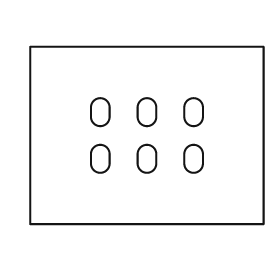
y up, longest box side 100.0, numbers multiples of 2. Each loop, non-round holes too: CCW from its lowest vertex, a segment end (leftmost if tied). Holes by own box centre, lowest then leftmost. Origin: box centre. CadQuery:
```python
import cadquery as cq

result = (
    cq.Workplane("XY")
    .moveTo(-50.0, -38.0)
    .lineTo(50.0, -38.0)
    .lineTo(50.0, 38.0)
    .lineTo(-50.0, 38.0)
    .close()
    .moveTo(-24.0, -12.0)
    .threePointArc((-20.0, -16.0), (-16.0, -12.0))
    .lineTo(-16.0, -8.0)
    .threePointArc((-20.0, -4.0), (-24.0, -8.0))
    .close()
    .moveTo(-4.0, -12.0)
    .threePointArc((0.0, -16.0), (4.0, -12.0))
    .lineTo(4.0, -8.0)
    .threePointArc((0.0, -4.0), (-4.0, -8.0))
    .close()
    .moveTo(16.0, -12.0)
    .threePointArc((20.0, -16.0), (24.0, -12.0))
    .lineTo(24.0, -8.0)
    .threePointArc((20.0, -4.0), (16.0, -8.0))
    .close()
    .moveTo(-24.0, 8.0)
    .threePointArc((-20.0, 4.0), (-16.0, 8.0))
    .lineTo(-16.0, 12.0)
    .threePointArc((-20.0, 16.0), (-24.0, 12.0))
    .close()
    .moveTo(-4.0, 8.0)
    .threePointArc((0.0, 4.0), (4.0, 8.0))
    .lineTo(4.0, 12.0)
    .threePointArc((0.0, 16.0), (-4.0, 12.0))
    .close()
    .moveTo(16.0, 8.0)
    .threePointArc((20.0, 4.0), (24.0, 8.0))
    .lineTo(24.0, 12.0)
    .threePointArc((20.0, 16.0), (16.0, 12.0))
    .close()
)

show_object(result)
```